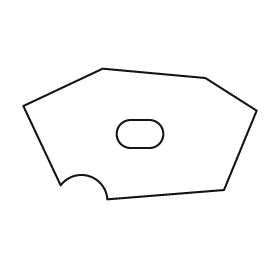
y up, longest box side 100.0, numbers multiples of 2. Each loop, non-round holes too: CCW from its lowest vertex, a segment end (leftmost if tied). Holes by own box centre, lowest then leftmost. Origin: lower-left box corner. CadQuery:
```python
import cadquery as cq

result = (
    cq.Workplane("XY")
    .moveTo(36.0, 0.0)
    .lineTo(86.0, 4.0)
    .lineTo(100.0, 38.0)
    .lineTo(78.0, 52.0)
    .lineTo(34.0, 56.0)
    .lineTo(0.0, 40.0)
    .lineTo(16.0, 6.0)
    .threePointArc((28.0, 10.0), (36.0, 0.0))
    .close()
    .moveTo(46.0, 22.0)
    .lineTo(54.0, 22.0)
    .threePointArc((60.0, 28.0), (54.0, 34.0))
    .lineTo(46.0, 34.0)
    .threePointArc((40.0, 28.0), (46.0, 22.0))
    .close()
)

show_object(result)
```